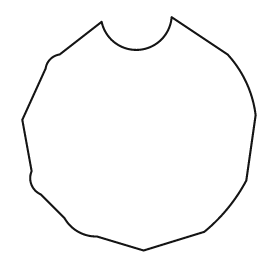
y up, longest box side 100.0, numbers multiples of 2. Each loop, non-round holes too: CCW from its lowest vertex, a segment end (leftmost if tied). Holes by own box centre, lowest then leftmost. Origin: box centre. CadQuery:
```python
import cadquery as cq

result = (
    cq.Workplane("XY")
    .moveTo(2.0, -50.0)
    .lineTo(28.0, -42.0)
    .threePointArc((38.0, -32.0), (46.0, -20.0))
    .lineTo(50.0, 8.0)
    .threePointArc((46.0, 22.0), (38.0, 34.0))
    .lineTo(14.0, 50.0)
    .threePointArc((0.0, 36.0), (-16.0, 48.0))
    .lineTo(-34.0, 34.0)
    .threePointArc((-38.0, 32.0), (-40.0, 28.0))
    .lineTo(-50.0, 6.0)
    .lineTo(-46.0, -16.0)
    .threePointArc((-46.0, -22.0), (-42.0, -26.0))
    .lineTo(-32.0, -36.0)
    .threePointArc((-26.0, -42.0), (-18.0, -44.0))
    .close()
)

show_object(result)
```